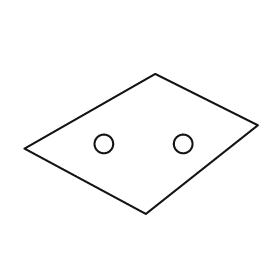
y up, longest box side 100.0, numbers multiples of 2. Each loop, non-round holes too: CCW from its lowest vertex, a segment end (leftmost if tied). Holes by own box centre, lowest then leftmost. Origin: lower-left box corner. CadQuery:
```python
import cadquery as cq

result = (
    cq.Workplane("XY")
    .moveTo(52.0, 0.0)
    .lineTo(100.0, 38.0)
    .lineTo(56.0, 60.0)
    .lineTo(0.0, 28.0)
    .close()
    .moveTo(34.0, 30.0)
    .circle(4.0)
    .moveTo(68.0, 30.0)
    .circle(4.0)
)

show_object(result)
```